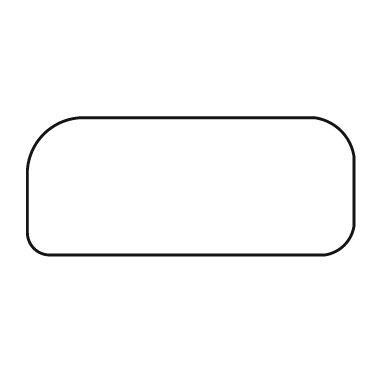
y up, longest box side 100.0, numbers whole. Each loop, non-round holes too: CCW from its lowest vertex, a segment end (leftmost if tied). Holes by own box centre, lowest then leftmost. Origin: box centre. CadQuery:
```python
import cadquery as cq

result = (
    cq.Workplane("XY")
    .moveTo(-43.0, -21.0)
    .lineTo(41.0, -21.0)
    .threePointArc((47.0, -18.0), (50.0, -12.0))
    .lineTo(50.0, 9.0)
    .threePointArc((46.0, 17.0), (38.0, 21.0))
    .lineTo(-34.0, 21.0)
    .threePointArc((-45.0, 16.0), (-50.0, 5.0))
    .lineTo(-50.0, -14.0)
    .threePointArc((-48.0, -19.0), (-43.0, -21.0))
    .close()
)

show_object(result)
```